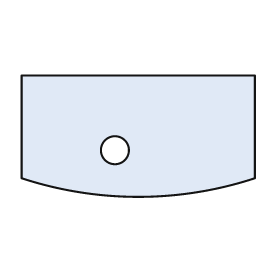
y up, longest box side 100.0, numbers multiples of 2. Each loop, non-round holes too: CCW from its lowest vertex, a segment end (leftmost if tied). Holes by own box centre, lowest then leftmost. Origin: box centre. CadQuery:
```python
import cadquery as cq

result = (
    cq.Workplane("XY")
    .moveTo(-50.0, -18.0)
    .threePointArc((0.0, -26.0), (50.0, -18.0))
    .lineTo(50.0, 26.0)
    .lineTo(-50.0, 26.0)
    .close()
    .moveTo(-10.0, -6.0)
    .circle(6.0)
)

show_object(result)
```